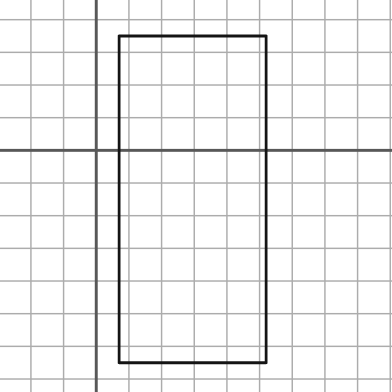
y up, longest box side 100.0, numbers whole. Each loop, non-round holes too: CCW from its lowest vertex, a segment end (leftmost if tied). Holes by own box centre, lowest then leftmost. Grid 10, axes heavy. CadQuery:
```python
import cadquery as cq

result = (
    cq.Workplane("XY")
    .moveTo(7.0, -65.0)
    .lineTo(52.0, -65.0)
    .lineTo(52.0, 35.0)
    .lineTo(7.0, 35.0)
    .close()
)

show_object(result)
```